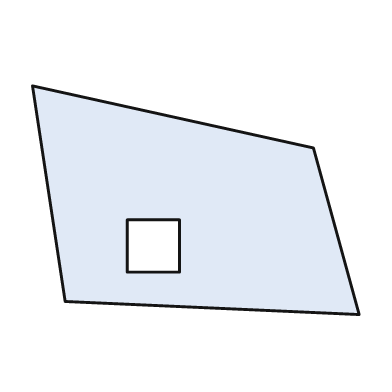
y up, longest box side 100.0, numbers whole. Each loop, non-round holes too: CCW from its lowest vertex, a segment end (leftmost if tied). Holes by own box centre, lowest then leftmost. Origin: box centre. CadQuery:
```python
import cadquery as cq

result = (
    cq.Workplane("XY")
    .moveTo(50.0, -35.0)
    .lineTo(36.0, 16.0)
    .lineTo(-50.0, 35.0)
    .lineTo(-40.0, -31.0)
    .close()
    .moveTo(-21.0, -22.0)
    .lineTo(-5.0, -22.0)
    .lineTo(-5.0, -6.0)
    .lineTo(-21.0, -6.0)
    .close()
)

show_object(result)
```